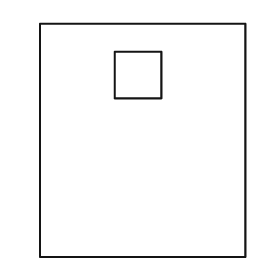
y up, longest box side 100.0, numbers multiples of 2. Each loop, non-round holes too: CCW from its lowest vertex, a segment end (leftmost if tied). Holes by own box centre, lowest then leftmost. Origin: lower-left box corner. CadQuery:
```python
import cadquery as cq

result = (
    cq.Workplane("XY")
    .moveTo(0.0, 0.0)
    .lineTo(88.0, 0.0)
    .lineTo(88.0, 100.0)
    .lineTo(0.0, 100.0)
    .close()
    .moveTo(32.0, 68.0)
    .lineTo(52.0, 68.0)
    .lineTo(52.0, 88.0)
    .lineTo(32.0, 88.0)
    .close()
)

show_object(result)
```